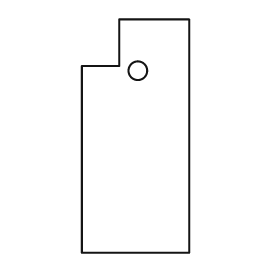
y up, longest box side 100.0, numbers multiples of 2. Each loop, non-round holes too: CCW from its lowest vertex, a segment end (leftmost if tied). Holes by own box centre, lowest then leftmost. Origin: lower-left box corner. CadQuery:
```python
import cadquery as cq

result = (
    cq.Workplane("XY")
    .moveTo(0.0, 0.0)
    .lineTo(46.0, 0.0)
    .lineTo(46.0, 100.0)
    .lineTo(16.0, 100.0)
    .lineTo(16.0, 80.0)
    .lineTo(0.0, 80.0)
    .close()
    .moveTo(24.0, 78.0)
    .circle(4.0)
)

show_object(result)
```